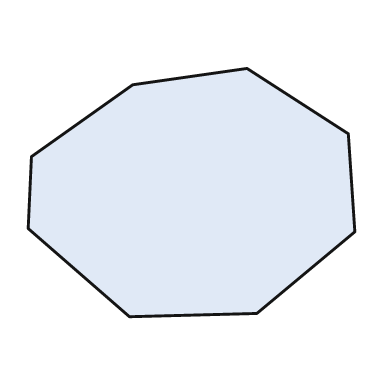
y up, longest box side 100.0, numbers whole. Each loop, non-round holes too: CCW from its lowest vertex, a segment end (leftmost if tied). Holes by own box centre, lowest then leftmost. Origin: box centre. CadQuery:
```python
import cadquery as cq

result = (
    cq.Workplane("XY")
    .moveTo(-19.0, -38.0)
    .lineTo(20.0, -37.0)
    .lineTo(50.0, -12.0)
    .lineTo(48.0, 18.0)
    .lineTo(17.0, 38.0)
    .lineTo(-18.0, 33.0)
    .lineTo(-49.0, 11.0)
    .lineTo(-50.0, -11.0)
    .close()
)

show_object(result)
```